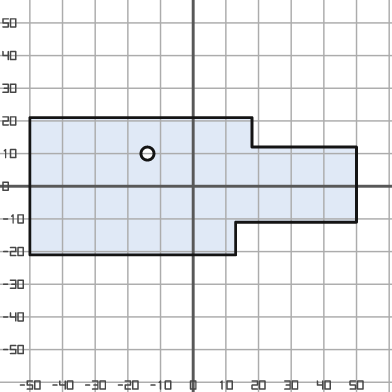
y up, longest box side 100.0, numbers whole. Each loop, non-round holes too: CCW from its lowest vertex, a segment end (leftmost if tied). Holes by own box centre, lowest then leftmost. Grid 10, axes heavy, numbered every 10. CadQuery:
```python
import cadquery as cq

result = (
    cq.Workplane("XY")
    .moveTo(-50.0, -21.0)
    .lineTo(13.0, -21.0)
    .lineTo(13.0, -11.0)
    .lineTo(50.0, -11.0)
    .lineTo(50.0, 12.0)
    .lineTo(18.0, 12.0)
    .lineTo(18.0, 21.0)
    .lineTo(-50.0, 21.0)
    .close()
    .moveTo(-14.0, 10.0)
    .circle(2.0)
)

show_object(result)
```